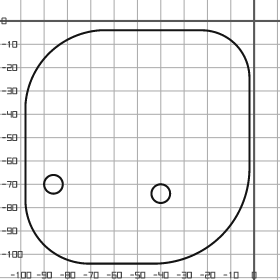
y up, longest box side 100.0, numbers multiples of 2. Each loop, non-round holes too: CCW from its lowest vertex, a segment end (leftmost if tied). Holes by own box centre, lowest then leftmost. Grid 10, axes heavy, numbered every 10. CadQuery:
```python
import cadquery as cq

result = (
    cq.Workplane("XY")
    .moveTo(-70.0, -104.0)
    .lineTo(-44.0, -104.0)
    .threePointArc((-14.0, -92.0), (-2.0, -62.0))
    .lineTo(-2.0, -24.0)
    .threePointArc((-8.0, -10.0), (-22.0, -4.0))
    .lineTo(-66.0, -4.0)
    .threePointArc((-88.0, -14.0), (-98.0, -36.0))
    .lineTo(-98.0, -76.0)
    .threePointArc((-90.0, -96.0), (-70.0, -104.0))
    .close()
    .moveTo(-40.0, -74.0)
    .circle(4.0)
    .moveTo(-86.0, -70.0)
    .circle(4.0)
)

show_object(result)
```